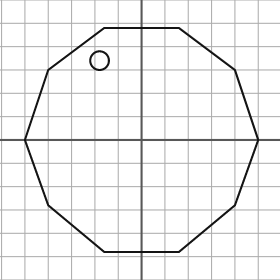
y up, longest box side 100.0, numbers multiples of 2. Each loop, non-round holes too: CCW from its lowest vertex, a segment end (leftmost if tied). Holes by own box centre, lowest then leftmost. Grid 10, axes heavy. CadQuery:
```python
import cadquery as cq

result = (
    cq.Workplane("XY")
    .moveTo(-16.0, -48.0)
    .lineTo(16.0, -48.0)
    .lineTo(40.0, -28.0)
    .lineTo(50.0, 0.0)
    .lineTo(40.0, 30.0)
    .lineTo(16.0, 48.0)
    .lineTo(-16.0, 48.0)
    .lineTo(-40.0, 30.0)
    .lineTo(-50.0, 0.0)
    .lineTo(-40.0, -28.0)
    .close()
    .moveTo(-18.0, 34.0)
    .circle(4.0)
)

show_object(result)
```